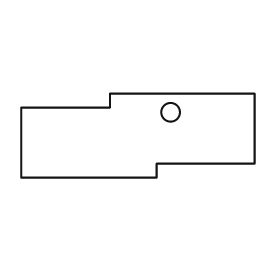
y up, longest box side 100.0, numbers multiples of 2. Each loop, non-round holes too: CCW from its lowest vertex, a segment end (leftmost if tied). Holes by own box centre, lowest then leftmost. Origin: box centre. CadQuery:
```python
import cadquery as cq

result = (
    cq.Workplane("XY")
    .moveTo(-50.0, -18.0)
    .lineTo(8.0, -18.0)
    .lineTo(8.0, -12.0)
    .lineTo(50.0, -12.0)
    .lineTo(50.0, 18.0)
    .lineTo(-12.0, 18.0)
    .lineTo(-12.0, 12.0)
    .lineTo(-50.0, 12.0)
    .close()
    .moveTo(14.0, 10.0)
    .circle(4.0)
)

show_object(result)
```